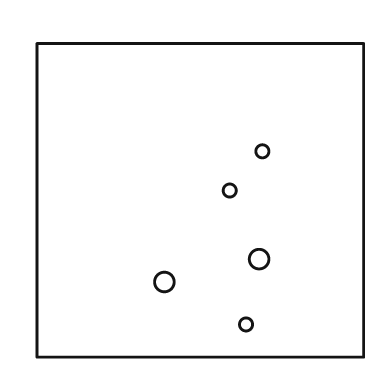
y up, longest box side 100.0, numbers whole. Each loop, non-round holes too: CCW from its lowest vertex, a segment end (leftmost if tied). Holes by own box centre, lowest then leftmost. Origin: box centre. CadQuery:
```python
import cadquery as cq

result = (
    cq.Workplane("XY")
    .moveTo(-50.0, -48.0)
    .lineTo(50.0, -48.0)
    .lineTo(50.0, 48.0)
    .lineTo(-50.0, 48.0)
    .close()
    .moveTo(14.0, -38.0)
    .circle(2.0)
    .moveTo(-11.0, -25.0)
    .circle(3.0)
    .moveTo(18.0, -18.0)
    .circle(3.0)
    .moveTo(9.0, 3.0)
    .circle(2.0)
    .moveTo(19.0, 15.0)
    .circle(2.0)
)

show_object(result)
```